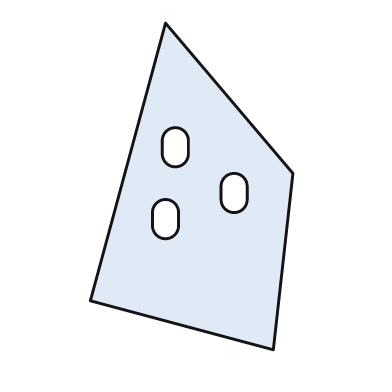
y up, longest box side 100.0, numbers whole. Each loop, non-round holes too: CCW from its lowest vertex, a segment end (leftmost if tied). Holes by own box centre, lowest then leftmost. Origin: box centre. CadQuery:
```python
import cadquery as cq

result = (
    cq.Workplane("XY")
    .moveTo(25.0, -50.0)
    .lineTo(31.0, 4.0)
    .lineTo(-8.0, 50.0)
    .lineTo(-31.0, -35.0)
    .close()
    .moveTo(-12.0, -12.0)
    .threePointArc((-8.0, -16.0), (-4.0, -12.0))
    .lineTo(-4.0, -8.0)
    .threePointArc((-8.0, -4.0), (-12.0, -8.0))
    .close()
    .moveTo(9.0, -4.0)
    .threePointArc((13.0, -8.0), (17.0, -4.0))
    .lineTo(17.0, 0.0)
    .threePointArc((13.0, 4.0), (9.0, 0.0))
    .close()
    .moveTo(-9.0, 10.0)
    .threePointArc((-5.0, 6.0), (-1.0, 10.0))
    .lineTo(-1.0, 14.0)
    .threePointArc((-5.0, 18.0), (-9.0, 14.0))
    .close()
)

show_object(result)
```